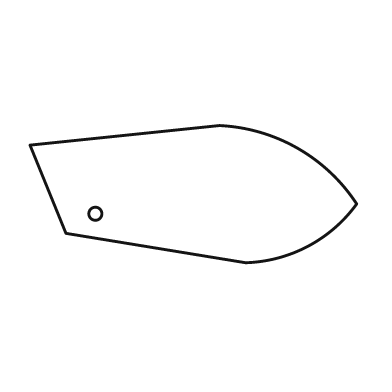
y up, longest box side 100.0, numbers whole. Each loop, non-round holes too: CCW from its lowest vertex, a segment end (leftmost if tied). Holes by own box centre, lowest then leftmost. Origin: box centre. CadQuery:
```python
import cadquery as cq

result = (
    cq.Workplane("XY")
    .moveTo(16.0, -21.0)
    .threePointArc((35.0, -16.0), (50.0, -3.0))
    .threePointArc((32.0, 14.0), (8.0, 21.0))
    .lineTo(-50.0, 15.0)
    .lineTo(-39.0, -12.0)
    .close()
    .moveTo(-30.0, -6.0)
    .circle(2.0)
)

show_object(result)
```